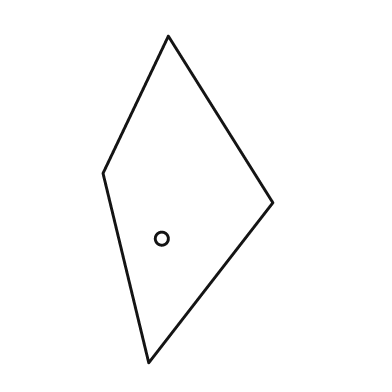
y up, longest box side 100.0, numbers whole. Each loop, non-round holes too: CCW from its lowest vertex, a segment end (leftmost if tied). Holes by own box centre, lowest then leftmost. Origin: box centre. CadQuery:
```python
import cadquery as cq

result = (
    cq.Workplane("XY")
    .moveTo(-12.0, -50.0)
    .lineTo(26.0, -1.0)
    .lineTo(-6.0, 50.0)
    .lineTo(-26.0, 8.0)
    .close()
    .moveTo(-8.0, -12.0)
    .circle(2.0)
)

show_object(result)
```